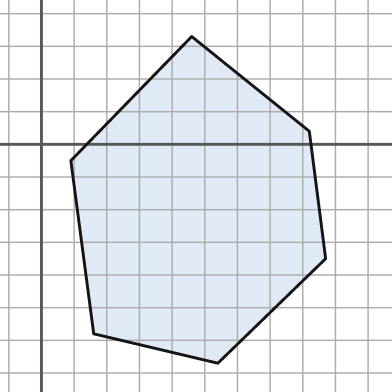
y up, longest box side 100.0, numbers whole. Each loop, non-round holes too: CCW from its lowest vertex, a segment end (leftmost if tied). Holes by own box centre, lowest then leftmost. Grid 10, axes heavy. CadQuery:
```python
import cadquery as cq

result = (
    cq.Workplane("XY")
    .moveTo(54.0, -67.0)
    .lineTo(87.0, -35.0)
    .lineTo(82.0, 4.0)
    .lineTo(46.0, 33.0)
    .lineTo(9.0, -5.0)
    .lineTo(16.0, -58.0)
    .close()
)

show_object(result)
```